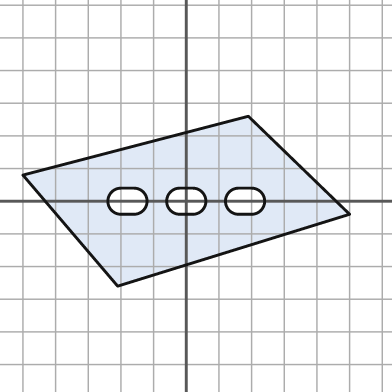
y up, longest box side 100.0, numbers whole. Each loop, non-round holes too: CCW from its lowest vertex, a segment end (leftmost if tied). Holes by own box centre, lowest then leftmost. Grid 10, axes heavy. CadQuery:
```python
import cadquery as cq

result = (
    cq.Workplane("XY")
    .moveTo(-21.0, -26.0)
    .lineTo(50.0, -4.0)
    .lineTo(19.0, 26.0)
    .lineTo(-50.0, 8.0)
    .close()
    .moveTo(-20.0, -4.0)
    .lineTo(-16.0, -4.0)
    .threePointArc((-12.0, 0.0), (-16.0, 4.0))
    .lineTo(-20.0, 4.0)
    .threePointArc((-24.0, 0.0), (-20.0, -4.0))
    .close()
    .moveTo(-2.0, -4.0)
    .lineTo(2.0, -4.0)
    .threePointArc((6.0, 0.0), (2.0, 4.0))
    .lineTo(-2.0, 4.0)
    .threePointArc((-6.0, 0.0), (-2.0, -4.0))
    .close()
    .moveTo(16.0, -4.0)
    .lineTo(20.0, -4.0)
    .threePointArc((24.0, 0.0), (20.0, 4.0))
    .lineTo(16.0, 4.0)
    .threePointArc((12.0, 0.0), (16.0, -4.0))
    .close()
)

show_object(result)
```